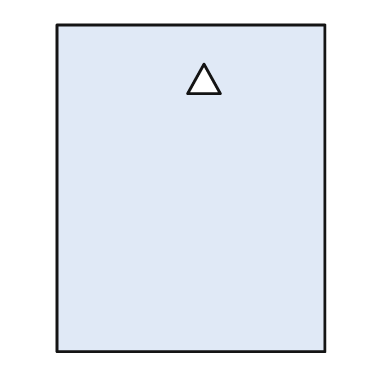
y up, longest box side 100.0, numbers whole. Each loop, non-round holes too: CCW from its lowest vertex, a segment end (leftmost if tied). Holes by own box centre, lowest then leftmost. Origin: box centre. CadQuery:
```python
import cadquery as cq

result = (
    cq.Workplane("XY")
    .moveTo(-41.0, -50.0)
    .lineTo(41.0, -50.0)
    .lineTo(41.0, 50.0)
    .lineTo(-41.0, 50.0)
    .close()
    .moveTo(-1.0, 29.0)
    .lineTo(9.0, 29.0)
    .lineTo(4.0, 38.0)
    .close()
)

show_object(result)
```